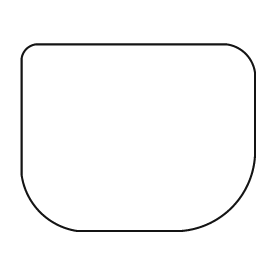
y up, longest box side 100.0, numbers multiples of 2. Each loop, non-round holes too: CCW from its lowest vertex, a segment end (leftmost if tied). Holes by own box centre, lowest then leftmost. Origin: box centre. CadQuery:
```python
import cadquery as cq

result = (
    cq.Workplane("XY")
    .moveTo(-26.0, -40.0)
    .lineTo(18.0, -40.0)
    .threePointArc((40.0, -30.0), (50.0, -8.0))
    .lineTo(50.0, 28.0)
    .threePointArc((46.0, 36.0), (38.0, 40.0))
    .lineTo(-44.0, 40.0)
    .threePointArc((-48.0, 38.0), (-50.0, 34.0))
    .lineTo(-50.0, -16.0)
    .threePointArc((-42.0, -32.0), (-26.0, -40.0))
    .close()
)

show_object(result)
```